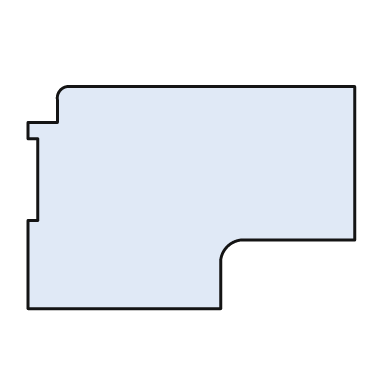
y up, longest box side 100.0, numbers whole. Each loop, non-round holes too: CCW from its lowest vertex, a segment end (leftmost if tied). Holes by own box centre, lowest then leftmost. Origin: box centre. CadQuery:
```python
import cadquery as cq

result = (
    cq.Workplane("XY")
    .moveTo(-50.0, -34.0)
    .lineTo(9.0, -34.0)
    .lineTo(9.0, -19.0)
    .threePointArc((11.0, -15.0), (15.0, -13.0))
    .lineTo(50.0, -13.0)
    .lineTo(50.0, 34.0)
    .lineTo(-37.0, 34.0)
    .threePointArc((-40.0, 33.0), (-41.0, 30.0))
    .lineTo(-41.0, 23.0)
    .lineTo(-50.0, 23.0)
    .lineTo(-50.0, 18.0)
    .lineTo(-47.0, 18.0)
    .lineTo(-47.0, -7.0)
    .lineTo(-50.0, -7.0)
    .close()
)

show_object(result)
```